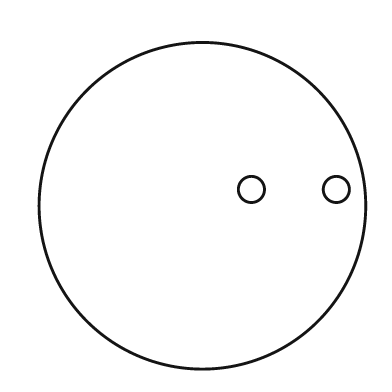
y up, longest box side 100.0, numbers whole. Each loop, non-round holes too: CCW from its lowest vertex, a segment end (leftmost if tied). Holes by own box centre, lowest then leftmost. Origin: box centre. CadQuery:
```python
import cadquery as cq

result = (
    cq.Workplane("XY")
    .moveTo(0.0, 0.0)
    .circle(50.0)
    .moveTo(15.0, 5.0)
    .circle(4.0)
    .moveTo(41.0, 5.0)
    .circle(4.0)
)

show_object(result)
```